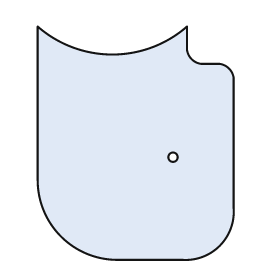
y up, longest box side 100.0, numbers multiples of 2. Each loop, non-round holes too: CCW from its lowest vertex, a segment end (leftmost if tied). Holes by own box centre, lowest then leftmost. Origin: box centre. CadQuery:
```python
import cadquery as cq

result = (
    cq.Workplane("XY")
    .moveTo(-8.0, -50.0)
    .lineTo(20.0, -50.0)
    .threePointArc((36.0, -44.0), (42.0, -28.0))
    .lineTo(42.0, 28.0)
    .threePointArc((40.0, 32.0), (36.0, 34.0))
    .lineTo(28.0, 34.0)
    .threePointArc((24.0, 36.0), (22.0, 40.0))
    .lineTo(22.0, 50.0)
    .threePointArc((-10.0, 38.0), (-42.0, 50.0))
    .lineTo(-42.0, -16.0)
    .threePointArc((-32.0, -40.0), (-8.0, -50.0))
    .close()
    .moveTo(16.0, -6.0)
    .circle(2.0)
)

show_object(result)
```